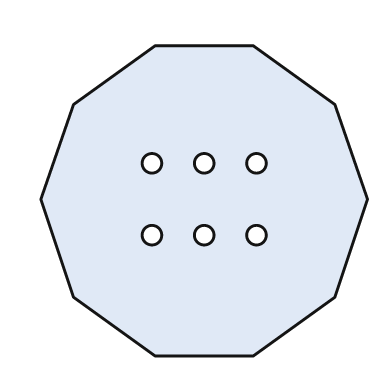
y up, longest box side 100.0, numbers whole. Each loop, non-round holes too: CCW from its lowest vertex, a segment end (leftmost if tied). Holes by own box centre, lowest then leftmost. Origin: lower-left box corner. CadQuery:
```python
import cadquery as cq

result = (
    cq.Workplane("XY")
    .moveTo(35.0, 0.0)
    .lineTo(65.0, 0.0)
    .lineTo(90.0, 18.0)
    .lineTo(100.0, 48.0)
    .lineTo(90.0, 77.0)
    .lineTo(65.0, 95.0)
    .lineTo(35.0, 95.0)
    .lineTo(10.0, 77.0)
    .lineTo(0.0, 48.0)
    .lineTo(10.0, 18.0)
    .close()
    .moveTo(34.0, 37.0)
    .circle(3.0)
    .moveTo(50.0, 37.0)
    .circle(3.0)
    .moveTo(66.0, 37.0)
    .circle(3.0)
    .moveTo(34.0, 59.0)
    .circle(3.0)
    .moveTo(50.0, 59.0)
    .circle(3.0)
    .moveTo(66.0, 59.0)
    .circle(3.0)
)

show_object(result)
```